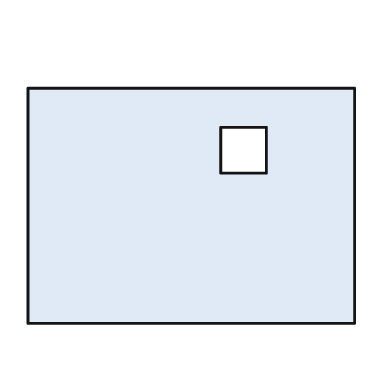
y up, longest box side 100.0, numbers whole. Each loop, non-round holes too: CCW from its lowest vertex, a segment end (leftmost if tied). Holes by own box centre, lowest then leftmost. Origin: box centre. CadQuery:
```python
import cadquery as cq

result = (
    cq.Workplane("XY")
    .moveTo(-50.0, -36.0)
    .lineTo(50.0, -36.0)
    .lineTo(50.0, 36.0)
    .lineTo(-50.0, 36.0)
    .close()
    .moveTo(9.0, 10.0)
    .lineTo(23.0, 10.0)
    .lineTo(23.0, 24.0)
    .lineTo(9.0, 24.0)
    .close()
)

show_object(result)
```